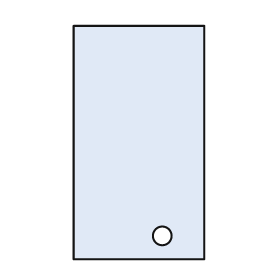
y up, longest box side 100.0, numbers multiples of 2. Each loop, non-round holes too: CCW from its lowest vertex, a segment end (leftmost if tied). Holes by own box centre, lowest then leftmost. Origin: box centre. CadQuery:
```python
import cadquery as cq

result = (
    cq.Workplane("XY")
    .moveTo(-28.0, -50.0)
    .lineTo(28.0, -50.0)
    .lineTo(28.0, 50.0)
    .lineTo(-28.0, 50.0)
    .close()
    .moveTo(10.0, -40.0)
    .circle(4.0)
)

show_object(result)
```